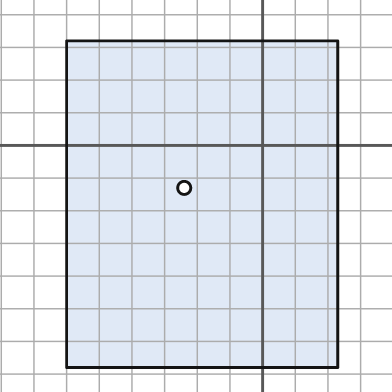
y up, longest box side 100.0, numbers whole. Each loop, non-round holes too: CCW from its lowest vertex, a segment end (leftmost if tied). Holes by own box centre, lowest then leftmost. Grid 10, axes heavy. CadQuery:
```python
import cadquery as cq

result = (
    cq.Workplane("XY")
    .moveTo(-60.0, -68.0)
    .lineTo(23.0, -68.0)
    .lineTo(23.0, 32.0)
    .lineTo(-60.0, 32.0)
    .close()
    .moveTo(-24.0, -13.0)
    .circle(2.0)
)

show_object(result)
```